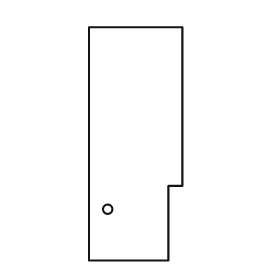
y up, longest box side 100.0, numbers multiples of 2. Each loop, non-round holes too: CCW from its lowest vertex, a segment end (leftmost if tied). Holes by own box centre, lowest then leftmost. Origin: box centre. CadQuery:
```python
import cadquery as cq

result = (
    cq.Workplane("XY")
    .moveTo(-20.0, -50.0)
    .lineTo(14.0, -50.0)
    .lineTo(14.0, -18.0)
    .lineTo(20.0, -18.0)
    .lineTo(20.0, 50.0)
    .lineTo(-20.0, 50.0)
    .close()
    .moveTo(-12.0, -28.0)
    .circle(2.0)
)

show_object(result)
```